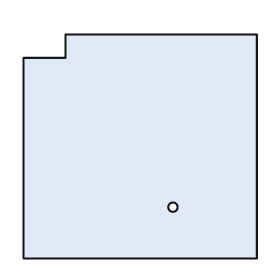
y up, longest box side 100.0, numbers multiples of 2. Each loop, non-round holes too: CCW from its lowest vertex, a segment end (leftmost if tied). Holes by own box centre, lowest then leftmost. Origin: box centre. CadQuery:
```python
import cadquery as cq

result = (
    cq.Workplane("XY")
    .moveTo(-50.0, -48.0)
    .lineTo(50.0, -48.0)
    .lineTo(50.0, 48.0)
    .lineTo(-32.0, 48.0)
    .lineTo(-32.0, 38.0)
    .lineTo(-50.0, 38.0)
    .close()
    .moveTo(14.0, -26.0)
    .circle(2.0)
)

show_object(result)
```